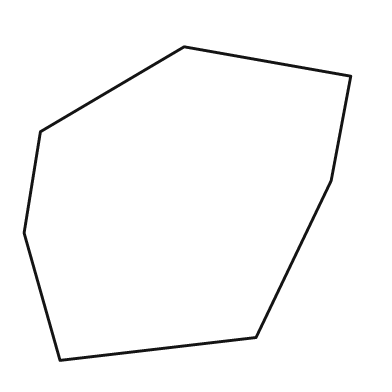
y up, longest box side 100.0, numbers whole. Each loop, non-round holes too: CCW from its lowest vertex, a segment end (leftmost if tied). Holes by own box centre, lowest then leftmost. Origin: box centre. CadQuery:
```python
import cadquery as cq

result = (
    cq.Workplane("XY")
    .moveTo(-39.0, -48.0)
    .lineTo(21.0, -41.0)
    .lineTo(44.0, 7.0)
    .lineTo(50.0, 39.0)
    .lineTo(-1.0, 48.0)
    .lineTo(-45.0, 22.0)
    .lineTo(-50.0, -9.0)
    .close()
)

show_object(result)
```